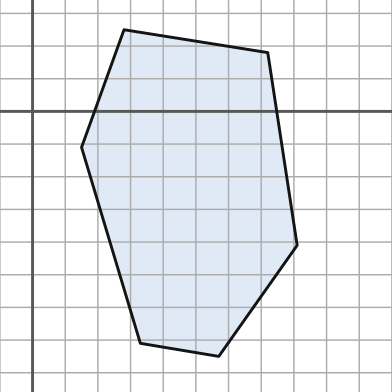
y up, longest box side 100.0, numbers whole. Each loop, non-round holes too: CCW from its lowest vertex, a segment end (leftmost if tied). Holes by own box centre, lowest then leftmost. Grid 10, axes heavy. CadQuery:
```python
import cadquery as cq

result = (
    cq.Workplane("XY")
    .moveTo(57.0, -75.0)
    .lineTo(81.0, -41.0)
    .lineTo(72.0, 18.0)
    .lineTo(28.0, 25.0)
    .lineTo(15.0, -11.0)
    .lineTo(33.0, -71.0)
    .close()
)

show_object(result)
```